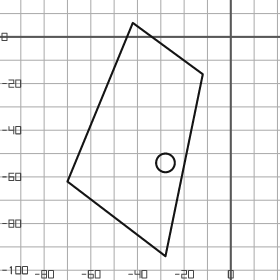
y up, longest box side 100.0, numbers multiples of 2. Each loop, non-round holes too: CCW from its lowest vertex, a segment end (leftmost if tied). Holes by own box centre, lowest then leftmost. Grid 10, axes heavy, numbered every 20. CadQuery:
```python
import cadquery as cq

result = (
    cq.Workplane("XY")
    .moveTo(-28.0, -94.0)
    .lineTo(-12.0, -16.0)
    .lineTo(-42.0, 6.0)
    .lineTo(-70.0, -62.0)
    .close()
    .moveTo(-28.0, -54.0)
    .circle(4.0)
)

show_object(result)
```